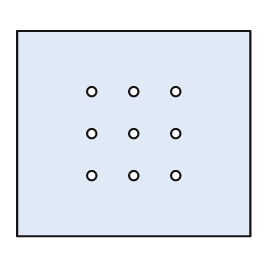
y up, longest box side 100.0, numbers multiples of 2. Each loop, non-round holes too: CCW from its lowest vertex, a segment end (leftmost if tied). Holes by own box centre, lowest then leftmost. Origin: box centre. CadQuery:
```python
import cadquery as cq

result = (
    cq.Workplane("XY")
    .moveTo(-50.0, -44.0)
    .lineTo(50.0, -44.0)
    .lineTo(50.0, 44.0)
    .lineTo(-50.0, 44.0)
    .close()
    .moveTo(-18.0, -18.0)
    .circle(2.0)
    .moveTo(0.0, -18.0)
    .circle(2.0)
    .moveTo(18.0, -18.0)
    .circle(2.0)
    .moveTo(-18.0, 0.0)
    .circle(2.0)
    .moveTo(0.0, 0.0)
    .circle(2.0)
    .moveTo(18.0, 0.0)
    .circle(2.0)
    .moveTo(-18.0, 18.0)
    .circle(2.0)
    .moveTo(0.0, 18.0)
    .circle(2.0)
    .moveTo(18.0, 18.0)
    .circle(2.0)
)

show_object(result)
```